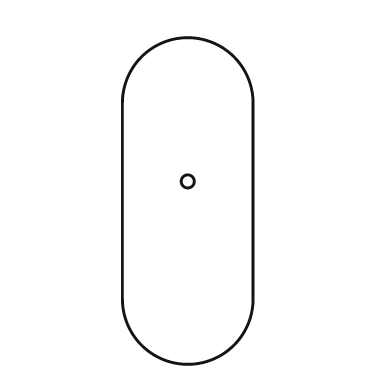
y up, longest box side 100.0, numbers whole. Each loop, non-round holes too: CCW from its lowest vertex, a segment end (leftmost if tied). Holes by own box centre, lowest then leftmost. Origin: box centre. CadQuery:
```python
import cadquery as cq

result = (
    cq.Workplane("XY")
    .moveTo(-20.0, -30.0)
    .threePointArc((0.0, -50.0), (20.0, -30.0))
    .lineTo(20.0, 30.0)
    .threePointArc((0.0, 50.0), (-20.0, 30.0))
    .close()
    .moveTo(0.0, 6.0)
    .circle(2.0)
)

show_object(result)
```